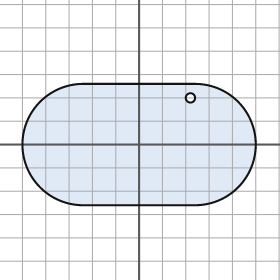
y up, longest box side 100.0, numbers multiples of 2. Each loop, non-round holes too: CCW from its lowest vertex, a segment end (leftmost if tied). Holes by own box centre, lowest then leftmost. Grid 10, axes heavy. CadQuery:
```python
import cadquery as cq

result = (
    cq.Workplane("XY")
    .moveTo(-24.0, -26.0)
    .lineTo(24.0, -26.0)
    .threePointArc((50.0, 0.0), (24.0, 26.0))
    .lineTo(-24.0, 26.0)
    .threePointArc((-50.0, 0.0), (-24.0, -26.0))
    .close()
    .moveTo(22.0, 20.0)
    .circle(2.0)
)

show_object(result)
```